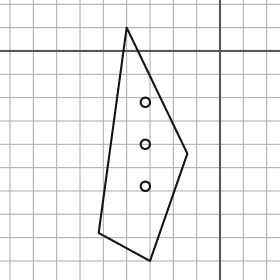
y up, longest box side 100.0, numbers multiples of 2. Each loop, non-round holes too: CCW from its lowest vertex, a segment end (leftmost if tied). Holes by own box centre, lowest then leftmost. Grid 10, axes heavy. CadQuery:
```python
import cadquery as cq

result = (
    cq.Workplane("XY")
    .moveTo(-30.0, -90.0)
    .lineTo(-14.0, -44.0)
    .lineTo(-40.0, 10.0)
    .lineTo(-52.0, -78.0)
    .close()
    .moveTo(-32.0, -58.0)
    .circle(2.0)
    .moveTo(-32.0, -40.0)
    .circle(2.0)
    .moveTo(-32.0, -22.0)
    .circle(2.0)
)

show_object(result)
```